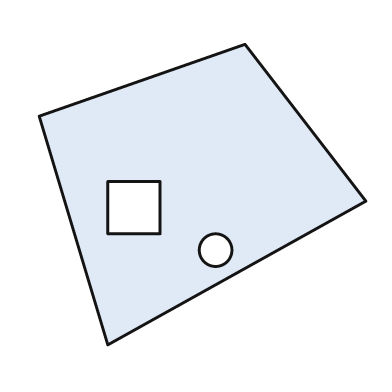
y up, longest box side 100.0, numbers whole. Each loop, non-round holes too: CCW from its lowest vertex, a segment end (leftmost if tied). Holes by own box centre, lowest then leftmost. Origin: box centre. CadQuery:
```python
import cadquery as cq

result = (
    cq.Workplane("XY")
    .moveTo(-29.0, -46.0)
    .lineTo(50.0, -2.0)
    .lineTo(13.0, 46.0)
    .lineTo(-50.0, 24.0)
    .close()
    .moveTo(4.0, -17.0)
    .circle(5.0)
    .moveTo(-29.0, -12.0)
    .lineTo(-13.0, -12.0)
    .lineTo(-13.0, 4.0)
    .lineTo(-29.0, 4.0)
    .close()
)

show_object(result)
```